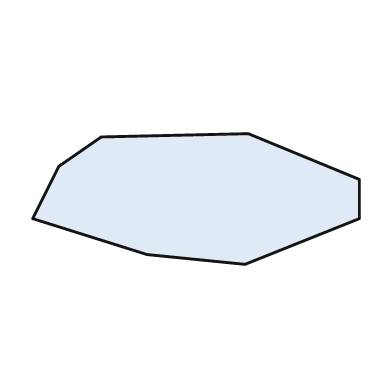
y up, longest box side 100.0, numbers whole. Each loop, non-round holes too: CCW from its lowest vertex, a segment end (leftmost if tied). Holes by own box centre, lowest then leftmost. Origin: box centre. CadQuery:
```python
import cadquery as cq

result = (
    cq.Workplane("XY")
    .moveTo(15.0, -20.0)
    .lineTo(50.0, -6.0)
    .lineTo(50.0, 6.0)
    .lineTo(16.0, 20.0)
    .lineTo(-29.0, 19.0)
    .lineTo(-42.0, 10.0)
    .lineTo(-50.0, -6.0)
    .lineTo(-15.0, -17.0)
    .close()
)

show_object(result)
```